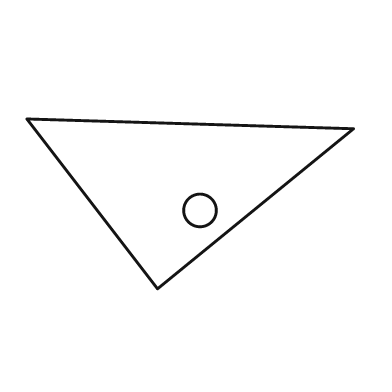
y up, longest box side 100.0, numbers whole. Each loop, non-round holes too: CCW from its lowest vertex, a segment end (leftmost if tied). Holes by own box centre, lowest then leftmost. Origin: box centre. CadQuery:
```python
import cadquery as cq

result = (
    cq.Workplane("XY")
    .moveTo(-10.0, -26.0)
    .lineTo(50.0, 23.0)
    .lineTo(-50.0, 26.0)
    .close()
    .moveTo(3.0, -2.0)
    .circle(5.0)
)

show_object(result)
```